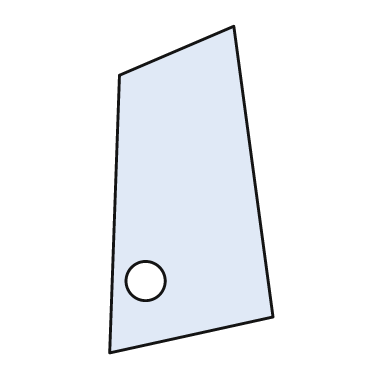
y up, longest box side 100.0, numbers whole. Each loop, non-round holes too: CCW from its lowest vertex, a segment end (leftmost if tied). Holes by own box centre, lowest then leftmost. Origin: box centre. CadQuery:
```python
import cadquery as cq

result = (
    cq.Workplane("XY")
    .moveTo(-25.0, -50.0)
    .lineTo(25.0, -39.0)
    .lineTo(13.0, 50.0)
    .lineTo(-22.0, 35.0)
    .close()
    .moveTo(-14.0, -28.0)
    .circle(6.0)
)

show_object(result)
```